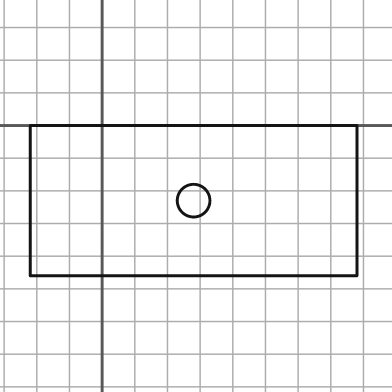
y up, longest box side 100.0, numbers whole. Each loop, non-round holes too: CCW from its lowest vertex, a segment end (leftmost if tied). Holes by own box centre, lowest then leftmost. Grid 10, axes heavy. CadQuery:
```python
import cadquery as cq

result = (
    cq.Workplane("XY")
    .moveTo(-22.0, -46.0)
    .lineTo(78.0, -46.0)
    .lineTo(78.0, 0.0)
    .lineTo(-22.0, 0.0)
    .close()
    .moveTo(28.0, -23.0)
    .circle(5.0)
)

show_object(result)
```